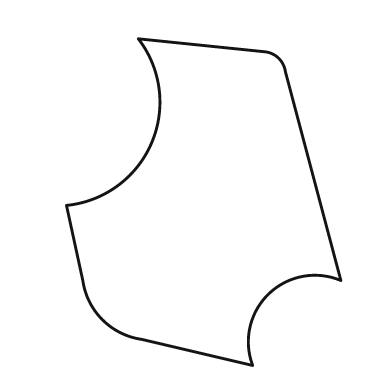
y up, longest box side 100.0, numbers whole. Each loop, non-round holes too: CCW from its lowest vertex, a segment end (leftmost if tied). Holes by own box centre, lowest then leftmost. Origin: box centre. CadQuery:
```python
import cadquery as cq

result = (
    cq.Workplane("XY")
    .moveTo(15.0, -50.0)
    .threePointArc((20.0, -28.0), (42.0, -24.0))
    .lineTo(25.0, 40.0)
    .threePointArc((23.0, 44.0), (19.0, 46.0))
    .lineTo(-20.0, 50.0)
    .threePointArc((-16.0, 18.0), (-42.0, -1.0))
    .lineTo(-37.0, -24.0)
    .threePointArc((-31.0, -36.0), (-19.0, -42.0))
    .close()
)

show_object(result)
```